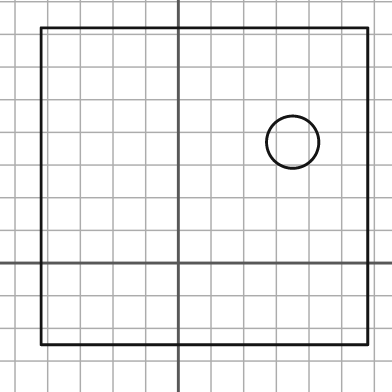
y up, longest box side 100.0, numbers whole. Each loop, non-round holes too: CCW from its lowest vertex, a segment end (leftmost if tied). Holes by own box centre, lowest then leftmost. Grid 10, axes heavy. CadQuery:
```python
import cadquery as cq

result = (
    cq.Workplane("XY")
    .moveTo(-42.0, -25.0)
    .lineTo(58.0, -25.0)
    .lineTo(58.0, 72.0)
    .lineTo(-42.0, 72.0)
    .close()
    .moveTo(35.0, 37.0)
    .circle(8.0)
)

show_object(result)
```